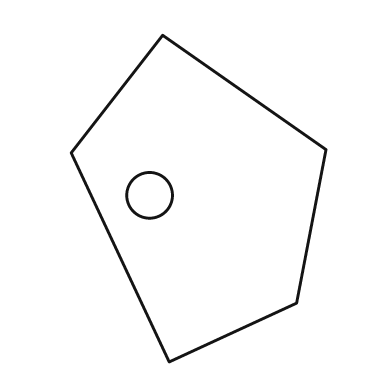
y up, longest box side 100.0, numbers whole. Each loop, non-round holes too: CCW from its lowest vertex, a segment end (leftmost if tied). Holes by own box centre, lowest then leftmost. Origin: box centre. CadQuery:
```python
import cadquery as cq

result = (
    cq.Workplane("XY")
    .moveTo(-9.0, -50.0)
    .lineTo(30.0, -32.0)
    .lineTo(39.0, 15.0)
    .lineTo(-11.0, 50.0)
    .lineTo(-39.0, 14.0)
    .close()
    .moveTo(-15.0, 1.0)
    .circle(7.0)
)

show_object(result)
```